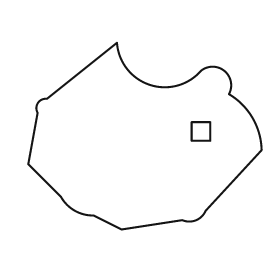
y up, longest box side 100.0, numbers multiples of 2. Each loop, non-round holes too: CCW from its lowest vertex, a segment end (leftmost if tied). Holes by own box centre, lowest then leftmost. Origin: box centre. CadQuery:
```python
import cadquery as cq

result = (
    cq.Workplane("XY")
    .moveTo(-10.0, -40.0)
    .lineTo(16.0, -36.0)
    .threePointArc((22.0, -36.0), (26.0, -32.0))
    .lineTo(50.0, -6.0)
    .threePointArc((46.0, 8.0), (36.0, 18.0))
    .threePointArc((34.0, 28.0), (24.0, 28.0))
    .threePointArc((2.0, 22.0), (-12.0, 40.0))
    .lineTo(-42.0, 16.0)
    .threePointArc((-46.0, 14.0), (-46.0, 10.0))
    .lineTo(-50.0, -12.0)
    .lineTo(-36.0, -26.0)
    .threePointArc((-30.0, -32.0), (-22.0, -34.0))
    .close()
    .moveTo(20.0, -2.0)
    .lineTo(28.0, -2.0)
    .lineTo(28.0, 6.0)
    .lineTo(20.0, 6.0)
    .close()
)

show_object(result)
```